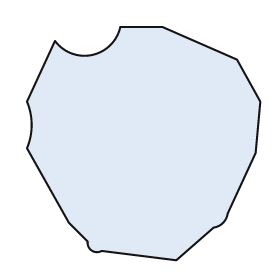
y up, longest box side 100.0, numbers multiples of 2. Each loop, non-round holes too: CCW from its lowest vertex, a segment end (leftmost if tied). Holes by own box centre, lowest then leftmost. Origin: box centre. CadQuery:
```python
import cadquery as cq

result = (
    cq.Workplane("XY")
    .moveTo(14.0, -50.0)
    .lineTo(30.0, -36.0)
    .threePointArc((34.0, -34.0), (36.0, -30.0))
    .lineTo(48.0, -4.0)
    .lineTo(50.0, 18.0)
    .lineTo(40.0, 36.0)
    .lineTo(8.0, 50.0)
    .lineTo(-10.0, 50.0)
    .threePointArc((-22.0, 38.0), (-38.0, 44.0))
    .lineTo(-50.0, 18.0)
    .threePointArc((-48.0, 8.0), (-50.0, -2.0))
    .lineTo(-32.0, -34.0)
    .lineTo(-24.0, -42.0)
    .threePointArc((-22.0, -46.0), (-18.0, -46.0))
    .close()
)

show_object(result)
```